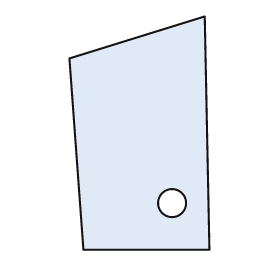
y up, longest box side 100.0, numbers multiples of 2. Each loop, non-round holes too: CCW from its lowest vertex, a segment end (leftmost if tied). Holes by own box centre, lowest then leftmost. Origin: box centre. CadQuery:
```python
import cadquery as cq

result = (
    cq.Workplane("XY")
    .moveTo(-24.0, -50.0)
    .lineTo(30.0, -50.0)
    .lineTo(28.0, 50.0)
    .lineTo(-30.0, 32.0)
    .close()
    .moveTo(14.0, -30.0)
    .circle(6.0)
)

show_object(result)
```